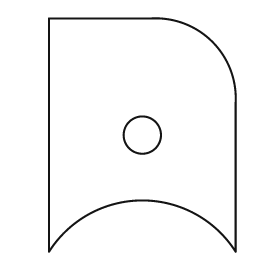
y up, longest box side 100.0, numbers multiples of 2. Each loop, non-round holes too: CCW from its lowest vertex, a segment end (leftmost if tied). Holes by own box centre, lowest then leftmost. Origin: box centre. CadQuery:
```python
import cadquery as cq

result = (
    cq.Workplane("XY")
    .moveTo(-40.0, -50.0)
    .threePointArc((0.0, -28.0), (40.0, -50.0))
    .lineTo(40.0, 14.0)
    .threePointArc((30.0, 40.0), (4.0, 50.0))
    .lineTo(-40.0, 50.0)
    .close()
    .moveTo(0.0, 0.0)
    .circle(8.0)
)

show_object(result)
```